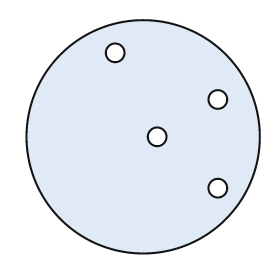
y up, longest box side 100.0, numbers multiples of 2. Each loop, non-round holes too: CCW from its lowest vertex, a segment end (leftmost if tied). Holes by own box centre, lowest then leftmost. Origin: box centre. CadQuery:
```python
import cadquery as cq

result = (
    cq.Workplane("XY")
    .moveTo(0.0, 0.0)
    .circle(50.0)
    .moveTo(32.0, -22.0)
    .circle(4.0)
    .moveTo(6.0, 0.0)
    .circle(4.0)
    .moveTo(32.0, 16.0)
    .circle(4.0)
    .moveTo(-12.0, 36.0)
    .circle(4.0)
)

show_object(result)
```